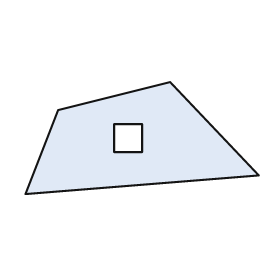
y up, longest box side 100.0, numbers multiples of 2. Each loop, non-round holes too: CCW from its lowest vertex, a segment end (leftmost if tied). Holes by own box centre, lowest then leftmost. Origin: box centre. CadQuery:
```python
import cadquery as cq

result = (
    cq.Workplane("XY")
    .moveTo(-50.0, -24.0)
    .lineTo(50.0, -16.0)
    .lineTo(12.0, 24.0)
    .lineTo(-36.0, 12.0)
    .close()
    .moveTo(-12.0, -6.0)
    .lineTo(0.0, -6.0)
    .lineTo(0.0, 6.0)
    .lineTo(-12.0, 6.0)
    .close()
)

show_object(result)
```